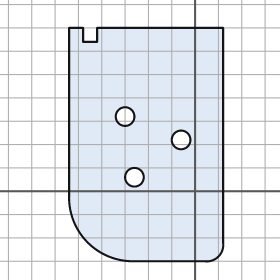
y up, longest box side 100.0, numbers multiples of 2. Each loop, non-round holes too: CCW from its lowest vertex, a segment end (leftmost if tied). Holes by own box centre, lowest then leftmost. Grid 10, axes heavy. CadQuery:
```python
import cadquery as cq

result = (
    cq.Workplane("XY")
    .moveTo(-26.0, -30.0)
    .lineTo(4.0, -30.0)
    .threePointArc((10.0, -28.0), (12.0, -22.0))
    .lineTo(12.0, 70.0)
    .lineTo(-42.0, 70.0)
    .lineTo(-42.0, 64.0)
    .lineTo(-48.0, 64.0)
    .lineTo(-48.0, 70.0)
    .lineTo(-54.0, 70.0)
    .lineTo(-54.0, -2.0)
    .threePointArc((-46.0, -22.0), (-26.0, -30.0))
    .close()
    .moveTo(-26.0, 6.0)
    .circle(4.0)
    .moveTo(-6.0, 22.0)
    .circle(4.0)
    .moveTo(-30.0, 32.0)
    .circle(4.0)
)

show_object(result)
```